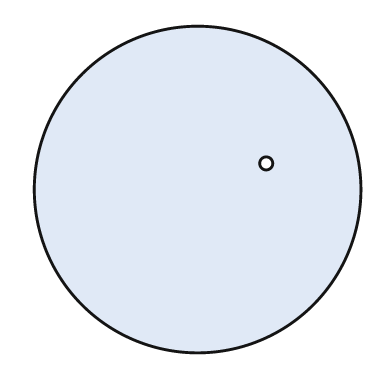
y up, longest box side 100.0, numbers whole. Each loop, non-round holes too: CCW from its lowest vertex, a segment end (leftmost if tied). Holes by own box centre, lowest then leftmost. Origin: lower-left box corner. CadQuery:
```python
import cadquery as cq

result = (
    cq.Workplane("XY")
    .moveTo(50.0, 50.0)
    .circle(50.0)
    .moveTo(71.0, 58.0)
    .circle(2.0)
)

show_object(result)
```